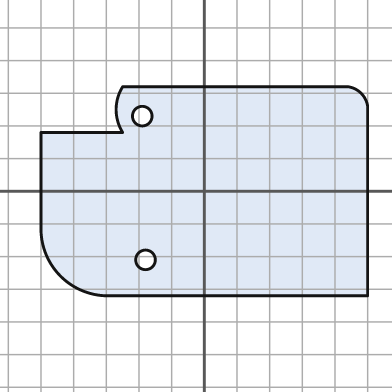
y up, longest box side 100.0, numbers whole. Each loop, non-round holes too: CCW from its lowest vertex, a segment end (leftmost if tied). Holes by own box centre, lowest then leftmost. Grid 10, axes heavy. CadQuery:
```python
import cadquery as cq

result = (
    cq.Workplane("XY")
    .moveTo(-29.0, -32.0)
    .lineTo(50.0, -32.0)
    .lineTo(50.0, 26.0)
    .threePointArc((48.0, 30.0), (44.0, 32.0))
    .lineTo(-25.0, 32.0)
    .threePointArc((-27.0, 25.0), (-25.0, 18.0))
    .lineTo(-50.0, 18.0)
    .lineTo(-50.0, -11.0)
    .threePointArc((-44.0, -26.0), (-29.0, -32.0))
    .close()
    .moveTo(-18.0, -21.0)
    .circle(3.0)
    .moveTo(-19.0, 23.0)
    .circle(3.0)
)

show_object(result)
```